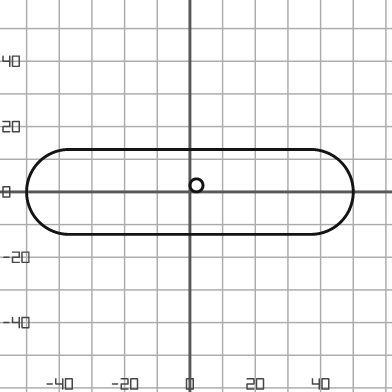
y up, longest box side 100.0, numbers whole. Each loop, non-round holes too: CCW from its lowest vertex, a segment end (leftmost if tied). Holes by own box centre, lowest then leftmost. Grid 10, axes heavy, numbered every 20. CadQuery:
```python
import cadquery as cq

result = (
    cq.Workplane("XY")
    .moveTo(-37.0, -13.0)
    .lineTo(37.0, -13.0)
    .threePointArc((50.0, 0.0), (37.0, 13.0))
    .lineTo(-37.0, 13.0)
    .threePointArc((-50.0, 0.0), (-37.0, -13.0))
    .close()
    .moveTo(2.0, 2.0)
    .circle(2.0)
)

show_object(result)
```